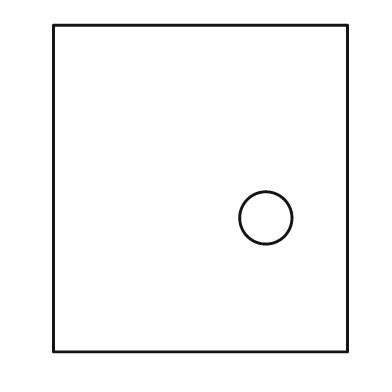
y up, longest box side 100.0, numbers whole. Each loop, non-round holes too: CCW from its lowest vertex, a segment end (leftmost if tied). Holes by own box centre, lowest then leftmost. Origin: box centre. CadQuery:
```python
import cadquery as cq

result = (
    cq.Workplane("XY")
    .moveTo(-45.0, -50.0)
    .lineTo(45.0, -50.0)
    .lineTo(45.0, 50.0)
    .lineTo(-45.0, 50.0)
    .close()
    .moveTo(20.0, -9.0)
    .circle(8.0)
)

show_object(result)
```